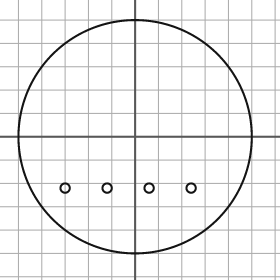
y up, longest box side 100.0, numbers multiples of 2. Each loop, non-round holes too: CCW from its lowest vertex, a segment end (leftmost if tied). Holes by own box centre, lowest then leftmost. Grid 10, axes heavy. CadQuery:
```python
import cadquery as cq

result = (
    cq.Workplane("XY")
    .moveTo(0.0, 0.0)
    .circle(50.0)
    .moveTo(-30.0, -22.0)
    .circle(2.0)
    .moveTo(-12.0, -22.0)
    .circle(2.0)
    .moveTo(6.0, -22.0)
    .circle(2.0)
    .moveTo(24.0, -22.0)
    .circle(2.0)
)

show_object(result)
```